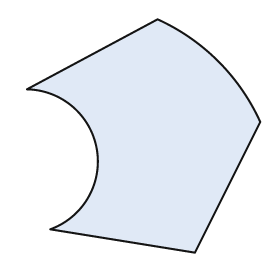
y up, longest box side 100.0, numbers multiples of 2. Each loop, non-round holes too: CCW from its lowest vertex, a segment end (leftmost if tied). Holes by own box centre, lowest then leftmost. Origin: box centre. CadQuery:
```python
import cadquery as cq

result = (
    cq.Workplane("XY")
    .moveTo(22.0, -50.0)
    .lineTo(50.0, 6.0)
    .threePointArc((32.0, 32.0), (6.0, 50.0))
    .lineTo(-50.0, 20.0)
    .threePointArc((-20.0, -6.0), (-40.0, -40.0))
    .close()
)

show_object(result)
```